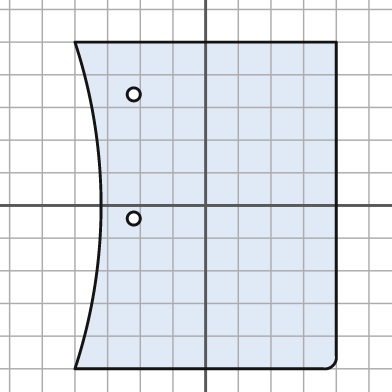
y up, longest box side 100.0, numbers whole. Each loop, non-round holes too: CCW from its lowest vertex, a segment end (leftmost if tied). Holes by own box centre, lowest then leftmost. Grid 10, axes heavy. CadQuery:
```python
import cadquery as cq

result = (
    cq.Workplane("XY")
    .moveTo(-40.0, -50.0)
    .lineTo(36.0, -50.0)
    .threePointArc((39.0, -49.0), (40.0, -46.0))
    .lineTo(40.0, 50.0)
    .lineTo(-40.0, 50.0)
    .threePointArc((-32.0, 0.0), (-40.0, -50.0))
    .close()
    .moveTo(-22.0, -4.0)
    .circle(2.0)
    .moveTo(-22.0, 34.0)
    .circle(2.0)
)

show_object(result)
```